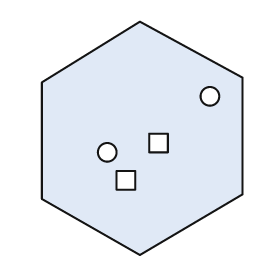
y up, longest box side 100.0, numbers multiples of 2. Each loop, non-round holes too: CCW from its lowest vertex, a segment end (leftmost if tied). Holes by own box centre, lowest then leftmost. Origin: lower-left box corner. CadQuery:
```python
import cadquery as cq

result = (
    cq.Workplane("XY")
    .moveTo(42.0, 0.0)
    .lineTo(86.0, 26.0)
    .lineTo(86.0, 76.0)
    .lineTo(42.0, 100.0)
    .lineTo(0.0, 74.0)
    .lineTo(0.0, 24.0)
    .close()
    .moveTo(32.0, 28.0)
    .lineTo(40.0, 28.0)
    .lineTo(40.0, 36.0)
    .lineTo(32.0, 36.0)
    .close()
    .moveTo(28.0, 44.0)
    .circle(4.0)
    .moveTo(46.0, 44.0)
    .lineTo(54.0, 44.0)
    .lineTo(54.0, 52.0)
    .lineTo(46.0, 52.0)
    .close()
    .moveTo(72.0, 68.0)
    .circle(4.0)
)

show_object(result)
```